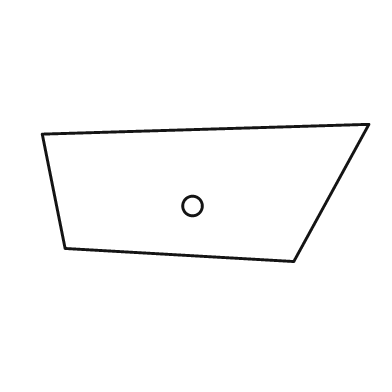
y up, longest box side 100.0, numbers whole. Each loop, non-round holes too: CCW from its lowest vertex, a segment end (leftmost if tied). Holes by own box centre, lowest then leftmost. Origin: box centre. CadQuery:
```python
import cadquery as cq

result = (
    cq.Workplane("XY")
    .moveTo(27.0, -21.0)
    .lineTo(50.0, 21.0)
    .lineTo(-50.0, 18.0)
    .lineTo(-43.0, -17.0)
    .close()
    .moveTo(-4.0, -4.0)
    .circle(3.0)
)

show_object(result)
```